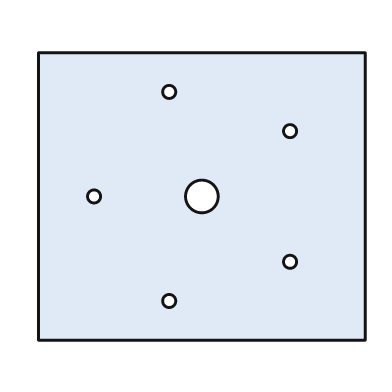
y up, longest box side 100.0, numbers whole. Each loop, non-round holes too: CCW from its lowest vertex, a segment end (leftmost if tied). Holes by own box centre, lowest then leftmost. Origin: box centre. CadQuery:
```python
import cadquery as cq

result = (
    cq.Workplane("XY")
    .moveTo(-50.0, -44.0)
    .lineTo(50.0, -44.0)
    .lineTo(50.0, 44.0)
    .lineTo(-50.0, 44.0)
    .close()
    .moveTo(-10.0, -32.0)
    .circle(2.0)
    .moveTo(27.0, -20.0)
    .circle(2.0)
    .moveTo(-33.0, 0.0)
    .circle(2.0)
    .moveTo(0.0, 0.0)
    .circle(5.0)
    .moveTo(27.0, 20.0)
    .circle(2.0)
    .moveTo(-10.0, 32.0)
    .circle(2.0)
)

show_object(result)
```